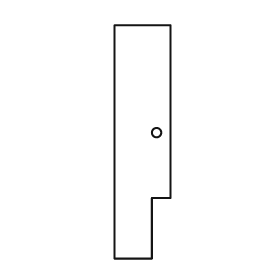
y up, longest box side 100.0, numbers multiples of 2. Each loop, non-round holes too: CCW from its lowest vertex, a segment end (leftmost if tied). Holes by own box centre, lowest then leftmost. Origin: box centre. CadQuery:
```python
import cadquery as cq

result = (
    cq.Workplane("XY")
    .moveTo(-12.0, -50.0)
    .lineTo(4.0, -50.0)
    .lineTo(4.0, -24.0)
    .lineTo(12.0, -24.0)
    .lineTo(12.0, 50.0)
    .lineTo(-12.0, 50.0)
    .close()
    .moveTo(6.0, 4.0)
    .circle(2.0)
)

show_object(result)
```